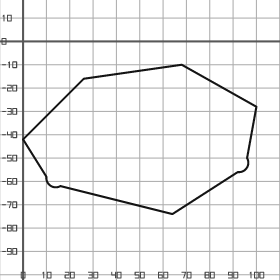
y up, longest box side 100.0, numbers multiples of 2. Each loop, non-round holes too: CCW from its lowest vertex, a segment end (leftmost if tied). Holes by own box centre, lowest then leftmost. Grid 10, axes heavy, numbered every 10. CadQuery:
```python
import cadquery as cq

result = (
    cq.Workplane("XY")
    .moveTo(64.0, -74.0)
    .lineTo(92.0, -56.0)
    .threePointArc((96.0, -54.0), (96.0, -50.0))
    .lineTo(100.0, -28.0)
    .lineTo(68.0, -10.0)
    .lineTo(26.0, -16.0)
    .lineTo(0.0, -42.0)
    .lineTo(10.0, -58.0)
    .threePointArc((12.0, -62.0), (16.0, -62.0))
    .close()
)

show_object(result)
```